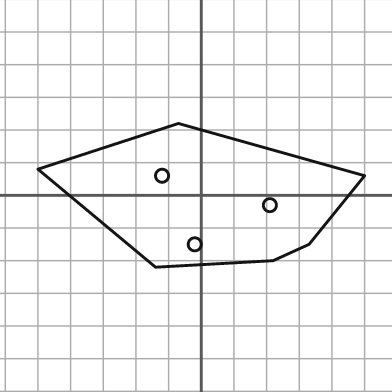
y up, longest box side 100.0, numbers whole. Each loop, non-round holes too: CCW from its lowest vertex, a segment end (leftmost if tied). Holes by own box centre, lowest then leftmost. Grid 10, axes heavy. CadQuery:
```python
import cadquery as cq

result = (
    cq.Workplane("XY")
    .moveTo(-14.0, -22.0)
    .lineTo(22.0, -20.0)
    .lineTo(33.0, -15.0)
    .lineTo(50.0, 6.0)
    .lineTo(-7.0, 22.0)
    .lineTo(-50.0, 8.0)
    .close()
    .moveTo(-2.0, -15.0)
    .circle(2.0)
    .moveTo(21.0, -3.0)
    .circle(2.0)
    .moveTo(-12.0, 6.0)
    .circle(2.0)
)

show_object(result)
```